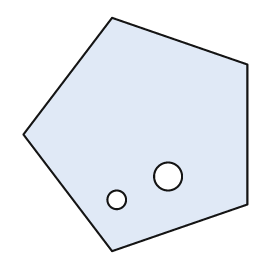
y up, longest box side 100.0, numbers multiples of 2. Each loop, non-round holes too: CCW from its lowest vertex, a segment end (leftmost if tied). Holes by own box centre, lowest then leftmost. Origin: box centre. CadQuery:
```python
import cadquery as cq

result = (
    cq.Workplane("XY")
    .moveTo(-10.0, -50.0)
    .lineTo(48.0, -30.0)
    .lineTo(48.0, 30.0)
    .lineTo(-10.0, 50.0)
    .lineTo(-48.0, 0.0)
    .close()
    .moveTo(-8.0, -28.0)
    .circle(4.0)
    .moveTo(14.0, -18.0)
    .circle(6.0)
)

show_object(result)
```